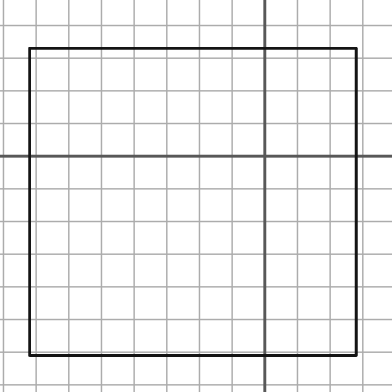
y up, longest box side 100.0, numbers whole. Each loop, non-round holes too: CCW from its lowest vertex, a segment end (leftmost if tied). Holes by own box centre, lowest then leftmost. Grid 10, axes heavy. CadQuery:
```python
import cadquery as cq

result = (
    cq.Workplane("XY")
    .moveTo(-72.0, -61.0)
    .lineTo(28.0, -61.0)
    .lineTo(28.0, 33.0)
    .lineTo(-72.0, 33.0)
    .close()
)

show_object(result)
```